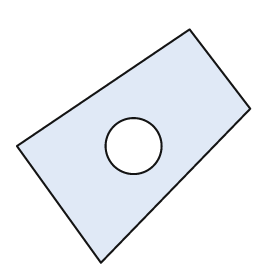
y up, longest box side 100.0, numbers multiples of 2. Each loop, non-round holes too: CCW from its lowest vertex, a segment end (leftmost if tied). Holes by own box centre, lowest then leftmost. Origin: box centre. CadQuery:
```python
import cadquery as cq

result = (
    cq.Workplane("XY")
    .moveTo(-14.0, -50.0)
    .lineTo(50.0, 16.0)
    .lineTo(24.0, 50.0)
    .lineTo(-50.0, 0.0)
    .close()
    .moveTo(0.0, 0.0)
    .circle(12.0)
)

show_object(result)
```